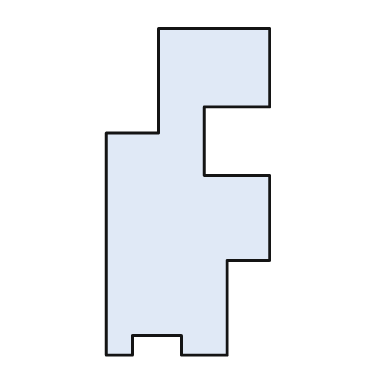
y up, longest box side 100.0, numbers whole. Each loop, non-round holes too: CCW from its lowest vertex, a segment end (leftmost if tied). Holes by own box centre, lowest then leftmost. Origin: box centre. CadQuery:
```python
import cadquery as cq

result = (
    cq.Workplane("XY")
    .moveTo(-25.0, -50.0)
    .lineTo(-17.0, -50.0)
    .lineTo(-17.0, -44.0)
    .lineTo(-2.0, -44.0)
    .lineTo(-2.0, -50.0)
    .lineTo(12.0, -50.0)
    .lineTo(12.0, -21.0)
    .lineTo(25.0, -21.0)
    .lineTo(25.0, 5.0)
    .lineTo(5.0, 5.0)
    .lineTo(5.0, 26.0)
    .lineTo(25.0, 26.0)
    .lineTo(25.0, 50.0)
    .lineTo(-9.0, 50.0)
    .lineTo(-9.0, 18.0)
    .lineTo(-25.0, 18.0)
    .close()
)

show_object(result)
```